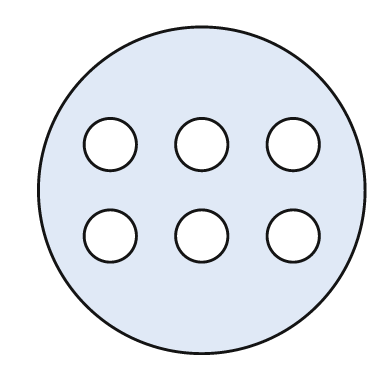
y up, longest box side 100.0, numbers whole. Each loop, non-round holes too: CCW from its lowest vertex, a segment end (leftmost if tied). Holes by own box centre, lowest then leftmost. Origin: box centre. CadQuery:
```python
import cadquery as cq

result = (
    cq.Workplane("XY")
    .moveTo(0.0, 0.0)
    .circle(50.0)
    .moveTo(-28.0, -14.0)
    .circle(8.0)
    .moveTo(0.0, -14.0)
    .circle(8.0)
    .moveTo(28.0, -14.0)
    .circle(8.0)
    .moveTo(-28.0, 14.0)
    .circle(8.0)
    .moveTo(0.0, 14.0)
    .circle(8.0)
    .moveTo(28.0, 14.0)
    .circle(8.0)
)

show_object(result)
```